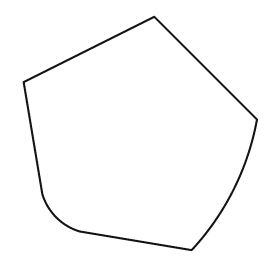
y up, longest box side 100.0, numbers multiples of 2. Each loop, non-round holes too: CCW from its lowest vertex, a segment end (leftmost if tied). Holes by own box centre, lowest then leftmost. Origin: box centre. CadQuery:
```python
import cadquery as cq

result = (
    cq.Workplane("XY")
    .moveTo(22.0, -50.0)
    .threePointArc((40.0, -24.0), (50.0, 6.0))
    .lineTo(6.0, 50.0)
    .lineTo(-50.0, 22.0)
    .lineTo(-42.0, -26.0)
    .threePointArc((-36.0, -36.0), (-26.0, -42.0))
    .close()
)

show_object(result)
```